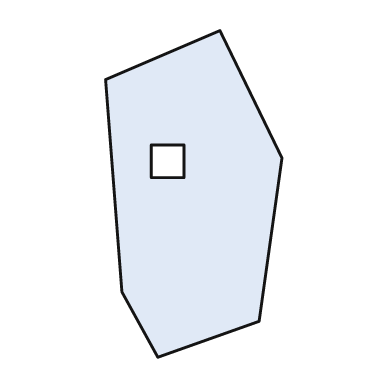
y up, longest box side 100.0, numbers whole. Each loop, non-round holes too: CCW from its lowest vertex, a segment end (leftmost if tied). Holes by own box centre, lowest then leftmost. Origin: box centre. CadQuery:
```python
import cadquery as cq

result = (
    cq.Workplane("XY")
    .moveTo(-11.0, -50.0)
    .lineTo(20.0, -39.0)
    .lineTo(27.0, 11.0)
    .lineTo(8.0, 50.0)
    .lineTo(-27.0, 35.0)
    .lineTo(-22.0, -30.0)
    .close()
    .moveTo(-13.0, 5.0)
    .lineTo(-3.0, 5.0)
    .lineTo(-3.0, 15.0)
    .lineTo(-13.0, 15.0)
    .close()
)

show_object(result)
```